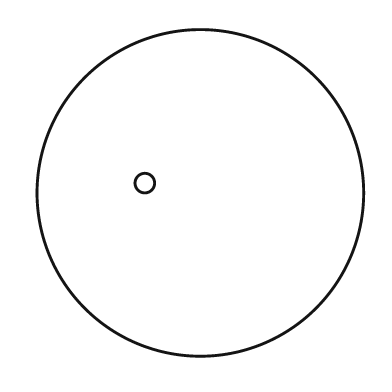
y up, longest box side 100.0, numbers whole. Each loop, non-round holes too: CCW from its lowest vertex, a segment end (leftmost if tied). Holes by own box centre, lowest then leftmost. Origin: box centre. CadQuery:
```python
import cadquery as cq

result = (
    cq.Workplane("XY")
    .moveTo(0.0, 0.0)
    .circle(50.0)
    .moveTo(-17.0, 3.0)
    .circle(3.0)
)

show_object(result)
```